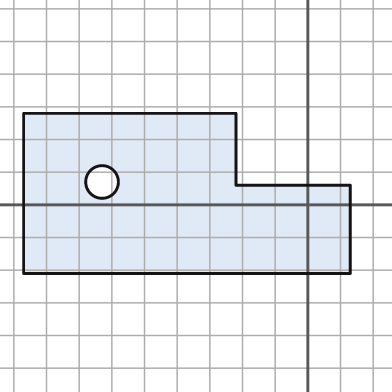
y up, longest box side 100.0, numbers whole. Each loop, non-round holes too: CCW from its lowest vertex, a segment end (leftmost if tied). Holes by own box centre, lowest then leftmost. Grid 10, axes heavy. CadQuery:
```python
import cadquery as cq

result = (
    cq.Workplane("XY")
    .moveTo(-87.0, -21.0)
    .lineTo(13.0, -21.0)
    .lineTo(13.0, 6.0)
    .lineTo(-22.0, 6.0)
    .lineTo(-22.0, 28.0)
    .lineTo(-87.0, 28.0)
    .close()
    .moveTo(-63.0, 7.0)
    .circle(5.0)
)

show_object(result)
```